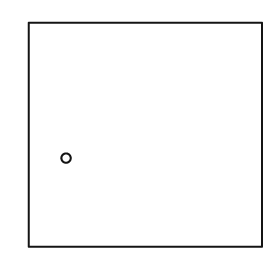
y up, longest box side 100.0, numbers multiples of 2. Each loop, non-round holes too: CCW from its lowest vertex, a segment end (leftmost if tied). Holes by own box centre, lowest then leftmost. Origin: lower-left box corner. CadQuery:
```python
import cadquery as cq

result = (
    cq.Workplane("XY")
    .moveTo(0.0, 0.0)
    .lineTo(100.0, 0.0)
    .lineTo(100.0, 96.0)
    .lineTo(0.0, 96.0)
    .close()
    .moveTo(16.0, 38.0)
    .circle(2.0)
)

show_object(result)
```